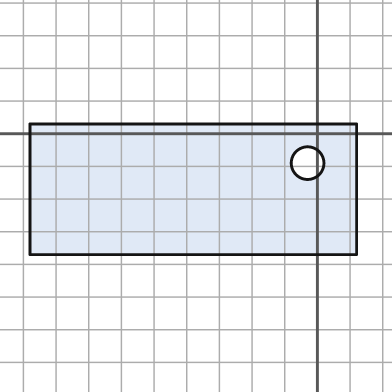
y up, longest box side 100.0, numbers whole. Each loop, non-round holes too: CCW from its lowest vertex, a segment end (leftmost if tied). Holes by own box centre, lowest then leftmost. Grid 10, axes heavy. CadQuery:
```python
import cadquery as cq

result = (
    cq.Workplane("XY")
    .moveTo(-88.0, -37.0)
    .lineTo(12.0, -37.0)
    .lineTo(12.0, 3.0)
    .lineTo(-88.0, 3.0)
    .close()
    .moveTo(-3.0, -9.0)
    .circle(5.0)
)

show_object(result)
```